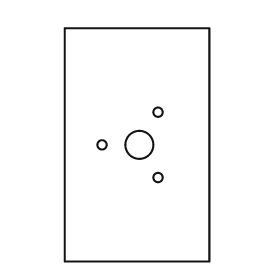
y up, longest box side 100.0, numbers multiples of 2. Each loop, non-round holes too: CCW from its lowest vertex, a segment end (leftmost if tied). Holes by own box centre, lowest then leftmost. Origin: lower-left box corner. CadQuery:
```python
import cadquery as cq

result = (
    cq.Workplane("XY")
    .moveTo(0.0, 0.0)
    .lineTo(62.0, 0.0)
    .lineTo(62.0, 100.0)
    .lineTo(0.0, 100.0)
    .close()
    .moveTo(40.0, 36.0)
    .circle(2.0)
    .moveTo(16.0, 50.0)
    .circle(2.0)
    .moveTo(32.0, 50.0)
    .circle(6.0)
    .moveTo(40.0, 64.0)
    .circle(2.0)
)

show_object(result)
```